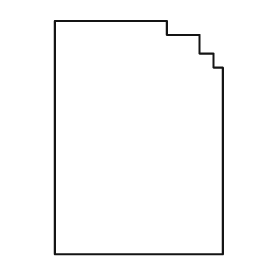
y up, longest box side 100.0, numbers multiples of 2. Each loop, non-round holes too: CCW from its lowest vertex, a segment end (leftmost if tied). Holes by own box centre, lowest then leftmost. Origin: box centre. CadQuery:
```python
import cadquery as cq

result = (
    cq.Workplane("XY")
    .moveTo(-36.0, -50.0)
    .lineTo(36.0, -50.0)
    .lineTo(36.0, 30.0)
    .lineTo(32.0, 30.0)
    .lineTo(32.0, 36.0)
    .lineTo(26.0, 36.0)
    .lineTo(26.0, 44.0)
    .lineTo(12.0, 44.0)
    .lineTo(12.0, 50.0)
    .lineTo(-36.0, 50.0)
    .close()
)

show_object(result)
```